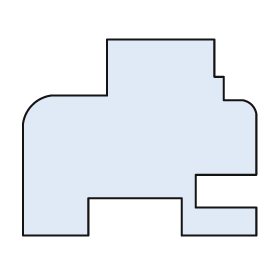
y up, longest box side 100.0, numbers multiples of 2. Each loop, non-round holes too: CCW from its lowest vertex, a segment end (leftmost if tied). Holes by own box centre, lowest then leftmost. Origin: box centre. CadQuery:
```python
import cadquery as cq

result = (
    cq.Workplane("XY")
    .moveTo(-50.0, -42.0)
    .lineTo(-22.0, -42.0)
    .lineTo(-22.0, -26.0)
    .lineTo(18.0, -26.0)
    .lineTo(18.0, -42.0)
    .lineTo(50.0, -42.0)
    .lineTo(50.0, -30.0)
    .lineTo(24.0, -30.0)
    .lineTo(24.0, -16.0)
    .lineTo(50.0, -16.0)
    .lineTo(50.0, 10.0)
    .threePointArc((48.0, 14.0), (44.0, 16.0))
    .lineTo(36.0, 16.0)
    .lineTo(36.0, 26.0)
    .lineTo(32.0, 26.0)
    .lineTo(32.0, 42.0)
    .lineTo(-14.0, 42.0)
    .lineTo(-14.0, 18.0)
    .lineTo(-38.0, 18.0)
    .threePointArc((-46.0, 14.0), (-50.0, 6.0))
    .close()
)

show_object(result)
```